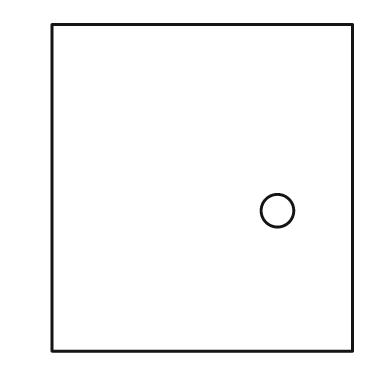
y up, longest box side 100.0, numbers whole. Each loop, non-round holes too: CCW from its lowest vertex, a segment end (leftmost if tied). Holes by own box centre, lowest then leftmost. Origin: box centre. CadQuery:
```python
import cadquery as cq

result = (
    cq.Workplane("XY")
    .moveTo(-46.0, -50.0)
    .lineTo(46.0, -50.0)
    .lineTo(46.0, 50.0)
    .lineTo(-46.0, 50.0)
    .close()
    .moveTo(23.0, -7.0)
    .circle(5.0)
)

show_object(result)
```